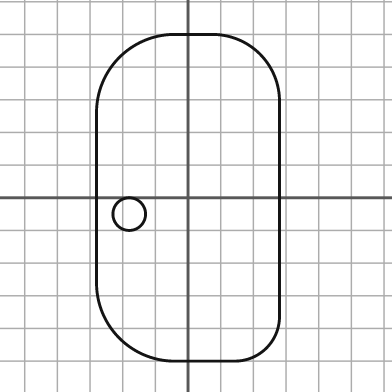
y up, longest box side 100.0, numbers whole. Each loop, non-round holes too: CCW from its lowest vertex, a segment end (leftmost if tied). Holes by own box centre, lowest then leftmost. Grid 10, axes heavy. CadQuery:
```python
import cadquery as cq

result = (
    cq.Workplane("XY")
    .moveTo(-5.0, -50.0)
    .lineTo(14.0, -50.0)
    .threePointArc((24.0, -46.0), (28.0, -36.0))
    .lineTo(28.0, 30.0)
    .threePointArc((22.0, 44.0), (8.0, 50.0))
    .lineTo(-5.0, 50.0)
    .threePointArc((-21.0, 43.0), (-28.0, 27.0))
    .lineTo(-28.0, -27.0)
    .threePointArc((-21.0, -43.0), (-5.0, -50.0))
    .close()
    .moveTo(-18.0, -5.0)
    .circle(5.0)
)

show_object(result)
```